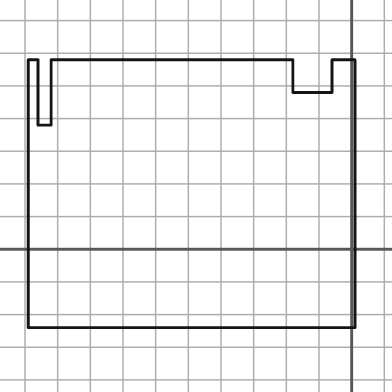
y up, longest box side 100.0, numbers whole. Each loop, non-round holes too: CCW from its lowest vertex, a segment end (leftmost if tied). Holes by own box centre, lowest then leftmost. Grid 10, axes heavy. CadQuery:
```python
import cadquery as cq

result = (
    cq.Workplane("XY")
    .moveTo(-99.0, -24.0)
    .lineTo(1.0, -24.0)
    .lineTo(1.0, 58.0)
    .lineTo(-6.0, 58.0)
    .lineTo(-6.0, 48.0)
    .lineTo(-18.0, 48.0)
    .lineTo(-18.0, 58.0)
    .lineTo(-92.0, 58.0)
    .lineTo(-92.0, 38.0)
    .lineTo(-96.0, 38.0)
    .lineTo(-96.0, 58.0)
    .lineTo(-99.0, 58.0)
    .close()
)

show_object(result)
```